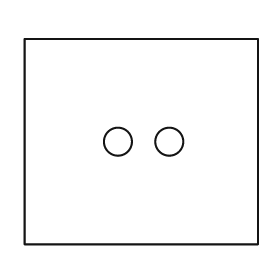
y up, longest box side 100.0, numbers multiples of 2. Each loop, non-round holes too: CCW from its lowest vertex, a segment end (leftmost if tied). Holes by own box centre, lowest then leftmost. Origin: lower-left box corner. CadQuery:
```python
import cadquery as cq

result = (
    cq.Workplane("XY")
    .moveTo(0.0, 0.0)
    .lineTo(100.0, 0.0)
    .lineTo(100.0, 88.0)
    .lineTo(0.0, 88.0)
    .close()
    .moveTo(40.0, 44.0)
    .circle(6.0)
    .moveTo(62.0, 44.0)
    .circle(6.0)
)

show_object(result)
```